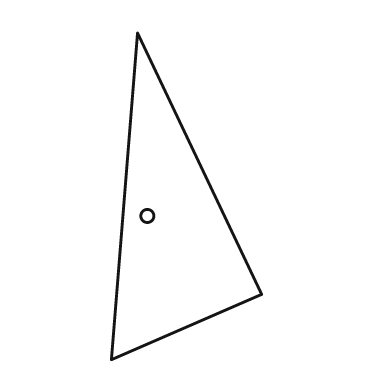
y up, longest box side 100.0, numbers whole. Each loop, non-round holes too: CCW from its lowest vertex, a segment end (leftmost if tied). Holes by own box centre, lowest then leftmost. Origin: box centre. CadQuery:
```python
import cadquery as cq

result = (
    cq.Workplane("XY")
    .moveTo(-23.0, -50.0)
    .lineTo(23.0, -30.0)
    .lineTo(-15.0, 50.0)
    .close()
    .moveTo(-12.0, -6.0)
    .circle(2.0)
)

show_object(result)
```